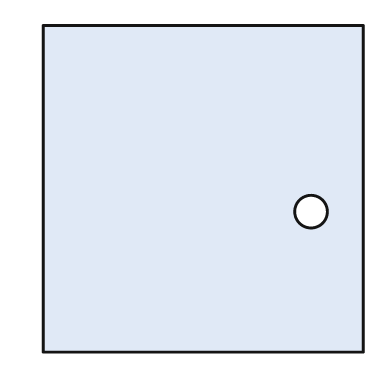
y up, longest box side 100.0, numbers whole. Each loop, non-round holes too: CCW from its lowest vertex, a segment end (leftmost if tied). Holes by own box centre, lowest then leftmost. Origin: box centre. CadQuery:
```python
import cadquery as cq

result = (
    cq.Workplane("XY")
    .moveTo(-49.0, -50.0)
    .lineTo(49.0, -50.0)
    .lineTo(49.0, 50.0)
    .lineTo(-49.0, 50.0)
    .close()
    .moveTo(33.0, -7.0)
    .circle(5.0)
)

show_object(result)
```